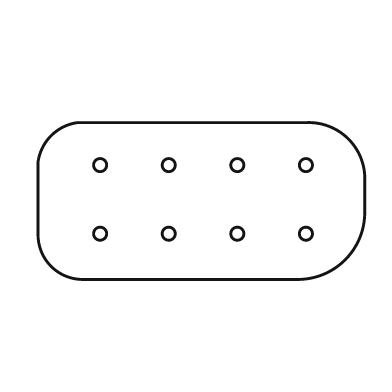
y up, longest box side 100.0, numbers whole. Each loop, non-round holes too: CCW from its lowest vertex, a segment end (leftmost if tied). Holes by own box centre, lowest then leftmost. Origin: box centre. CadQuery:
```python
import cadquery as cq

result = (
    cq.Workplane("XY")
    .moveTo(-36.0, -24.0)
    .lineTo(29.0, -24.0)
    .threePointArc((44.0, -18.0), (50.0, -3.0))
    .lineTo(50.0, 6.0)
    .threePointArc((45.0, 19.0), (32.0, 24.0))
    .lineTo(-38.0, 24.0)
    .threePointArc((-46.0, 20.0), (-50.0, 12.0))
    .lineTo(-50.0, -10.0)
    .threePointArc((-46.0, -20.0), (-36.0, -24.0))
    .close()
    .moveTo(-31.0, -10.0)
    .circle(2.0)
    .moveTo(-10.0, -10.0)
    .circle(2.0)
    .moveTo(11.0, -10.0)
    .circle(2.0)
    .moveTo(32.0, -10.0)
    .circle(2.0)
    .moveTo(-31.0, 11.0)
    .circle(2.0)
    .moveTo(-10.0, 11.0)
    .circle(2.0)
    .moveTo(11.0, 11.0)
    .circle(2.0)
    .moveTo(32.0, 11.0)
    .circle(2.0)
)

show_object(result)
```